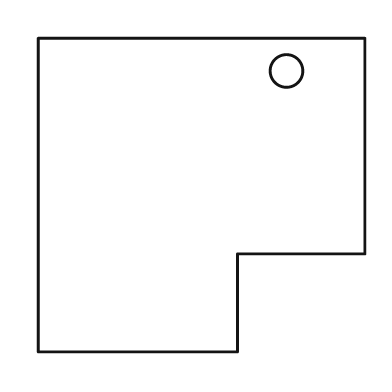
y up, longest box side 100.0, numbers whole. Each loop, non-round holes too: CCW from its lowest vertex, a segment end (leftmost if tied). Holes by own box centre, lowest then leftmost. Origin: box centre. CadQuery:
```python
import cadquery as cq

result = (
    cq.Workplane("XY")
    .moveTo(-50.0, -48.0)
    .lineTo(11.0, -48.0)
    .lineTo(11.0, -18.0)
    .lineTo(50.0, -18.0)
    .lineTo(50.0, 48.0)
    .lineTo(-50.0, 48.0)
    .close()
    .moveTo(26.0, 38.0)
    .circle(5.0)
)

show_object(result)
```